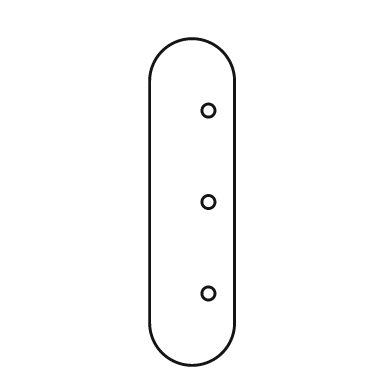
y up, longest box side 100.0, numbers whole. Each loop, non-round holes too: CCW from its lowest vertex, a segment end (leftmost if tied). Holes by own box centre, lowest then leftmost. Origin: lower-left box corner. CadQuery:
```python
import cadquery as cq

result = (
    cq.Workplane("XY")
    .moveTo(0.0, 13.0)
    .threePointArc((13.0, 0.0), (26.0, 13.0))
    .lineTo(26.0, 87.0)
    .threePointArc((13.0, 100.0), (0.0, 87.0))
    .close()
    .moveTo(18.0, 22.0)
    .circle(2.0)
    .moveTo(18.0, 50.0)
    .circle(2.0)
    .moveTo(18.0, 78.0)
    .circle(2.0)
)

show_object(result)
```